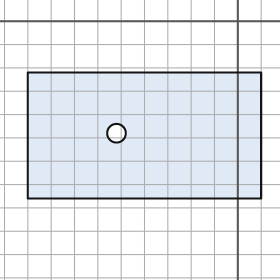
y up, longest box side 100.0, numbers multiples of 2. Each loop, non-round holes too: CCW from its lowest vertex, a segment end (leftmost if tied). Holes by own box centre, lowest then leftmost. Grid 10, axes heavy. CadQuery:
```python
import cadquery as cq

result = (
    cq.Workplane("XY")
    .moveTo(-90.0, -76.0)
    .lineTo(10.0, -76.0)
    .lineTo(10.0, -22.0)
    .lineTo(-90.0, -22.0)
    .close()
    .moveTo(-52.0, -48.0)
    .circle(4.0)
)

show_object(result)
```